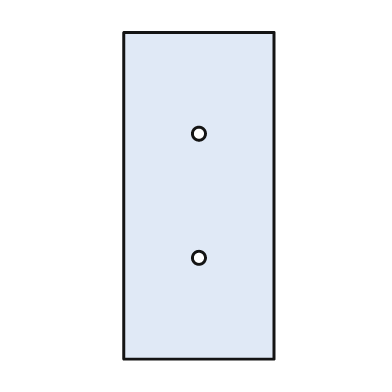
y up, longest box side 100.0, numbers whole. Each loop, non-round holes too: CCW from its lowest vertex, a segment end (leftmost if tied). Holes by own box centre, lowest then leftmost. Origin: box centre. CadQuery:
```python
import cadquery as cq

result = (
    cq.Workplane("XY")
    .moveTo(-23.0, -50.0)
    .lineTo(23.0, -50.0)
    .lineTo(23.0, 50.0)
    .lineTo(-23.0, 50.0)
    .close()
    .moveTo(0.0, -19.0)
    .circle(2.0)
    .moveTo(0.0, 19.0)
    .circle(2.0)
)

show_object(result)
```